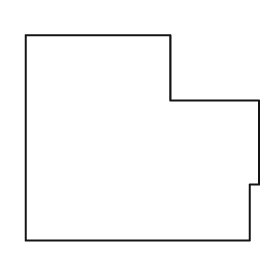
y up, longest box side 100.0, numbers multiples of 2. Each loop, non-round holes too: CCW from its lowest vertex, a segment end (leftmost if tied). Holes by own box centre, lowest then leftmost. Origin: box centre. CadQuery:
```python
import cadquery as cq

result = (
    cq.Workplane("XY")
    .moveTo(-50.0, -44.0)
    .lineTo(46.0, -44.0)
    .lineTo(46.0, -20.0)
    .lineTo(50.0, -20.0)
    .lineTo(50.0, 16.0)
    .lineTo(12.0, 16.0)
    .lineTo(12.0, 44.0)
    .lineTo(-50.0, 44.0)
    .close()
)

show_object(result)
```